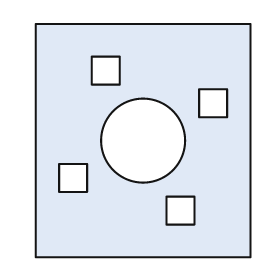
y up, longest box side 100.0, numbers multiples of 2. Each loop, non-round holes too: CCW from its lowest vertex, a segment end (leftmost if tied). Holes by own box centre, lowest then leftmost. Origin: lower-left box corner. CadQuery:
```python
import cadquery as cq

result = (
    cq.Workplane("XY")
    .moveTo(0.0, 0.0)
    .lineTo(92.0, 0.0)
    .lineTo(92.0, 100.0)
    .lineTo(0.0, 100.0)
    .close()
    .moveTo(56.0, 14.0)
    .lineTo(68.0, 14.0)
    .lineTo(68.0, 26.0)
    .lineTo(56.0, 26.0)
    .close()
    .moveTo(10.0, 28.0)
    .lineTo(22.0, 28.0)
    .lineTo(22.0, 40.0)
    .lineTo(10.0, 40.0)
    .close()
    .moveTo(46.0, 50.0)
    .circle(18.0)
    .moveTo(70.0, 60.0)
    .lineTo(82.0, 60.0)
    .lineTo(82.0, 72.0)
    .lineTo(70.0, 72.0)
    .close()
    .moveTo(24.0, 74.0)
    .lineTo(36.0, 74.0)
    .lineTo(36.0, 86.0)
    .lineTo(24.0, 86.0)
    .close()
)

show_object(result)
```